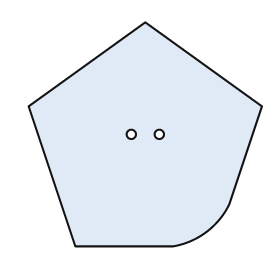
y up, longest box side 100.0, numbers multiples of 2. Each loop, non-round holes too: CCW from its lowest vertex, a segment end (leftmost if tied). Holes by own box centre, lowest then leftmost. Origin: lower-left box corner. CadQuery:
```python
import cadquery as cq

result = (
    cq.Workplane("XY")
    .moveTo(20.0, 0.0)
    .lineTo(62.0, 0.0)
    .threePointArc((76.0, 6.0), (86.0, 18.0))
    .lineTo(100.0, 60.0)
    .lineTo(50.0, 96.0)
    .lineTo(0.0, 60.0)
    .close()
    .moveTo(44.0, 48.0)
    .circle(2.0)
    .moveTo(56.0, 48.0)
    .circle(2.0)
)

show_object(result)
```